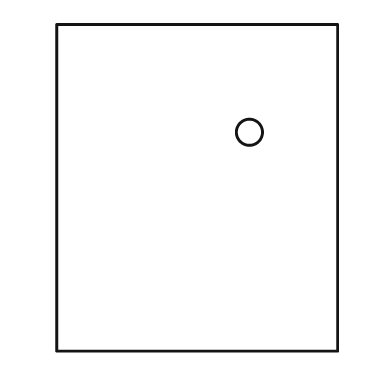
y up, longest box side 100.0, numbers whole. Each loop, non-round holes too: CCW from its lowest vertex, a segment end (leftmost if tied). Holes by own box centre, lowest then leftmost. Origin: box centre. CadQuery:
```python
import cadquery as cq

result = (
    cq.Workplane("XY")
    .moveTo(-43.0, -50.0)
    .lineTo(43.0, -50.0)
    .lineTo(43.0, 50.0)
    .lineTo(-43.0, 50.0)
    .close()
    .moveTo(16.0, 17.0)
    .circle(4.0)
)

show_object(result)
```